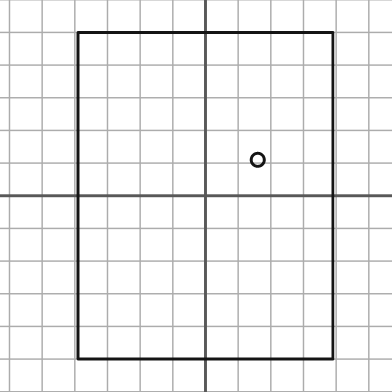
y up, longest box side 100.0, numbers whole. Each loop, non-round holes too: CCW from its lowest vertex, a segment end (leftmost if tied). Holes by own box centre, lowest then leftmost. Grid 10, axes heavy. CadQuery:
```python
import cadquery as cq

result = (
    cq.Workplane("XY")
    .moveTo(-39.0, -50.0)
    .lineTo(39.0, -50.0)
    .lineTo(39.0, 50.0)
    .lineTo(-39.0, 50.0)
    .close()
    .moveTo(16.0, 11.0)
    .circle(2.0)
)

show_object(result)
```